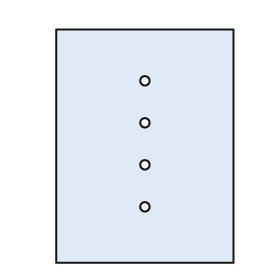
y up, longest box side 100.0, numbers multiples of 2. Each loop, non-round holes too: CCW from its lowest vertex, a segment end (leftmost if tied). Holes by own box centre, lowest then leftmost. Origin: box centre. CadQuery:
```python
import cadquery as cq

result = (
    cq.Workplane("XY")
    .moveTo(-38.0, -50.0)
    .lineTo(38.0, -50.0)
    .lineTo(38.0, 50.0)
    .lineTo(-38.0, 50.0)
    .close()
    .moveTo(0.0, -26.0)
    .circle(2.0)
    .moveTo(0.0, -8.0)
    .circle(2.0)
    .moveTo(0.0, 10.0)
    .circle(2.0)
    .moveTo(0.0, 28.0)
    .circle(2.0)
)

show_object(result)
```